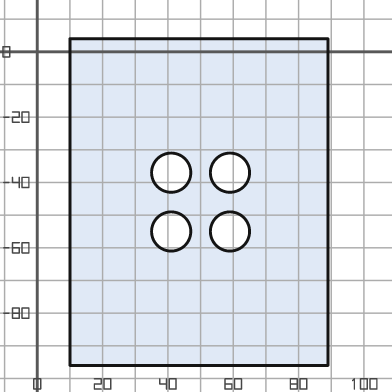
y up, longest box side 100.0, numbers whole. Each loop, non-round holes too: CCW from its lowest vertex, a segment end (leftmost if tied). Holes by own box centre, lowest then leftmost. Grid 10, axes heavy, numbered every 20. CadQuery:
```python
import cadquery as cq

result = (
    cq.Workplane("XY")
    .moveTo(10.0, -96.0)
    .lineTo(89.0, -96.0)
    .lineTo(89.0, 4.0)
    .lineTo(10.0, 4.0)
    .close()
    .moveTo(41.0, -55.0)
    .circle(6.0)
    .moveTo(59.0, -55.0)
    .circle(6.0)
    .moveTo(41.0, -37.0)
    .circle(6.0)
    .moveTo(59.0, -37.0)
    .circle(6.0)
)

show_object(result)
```